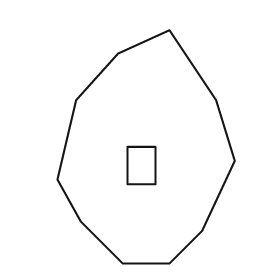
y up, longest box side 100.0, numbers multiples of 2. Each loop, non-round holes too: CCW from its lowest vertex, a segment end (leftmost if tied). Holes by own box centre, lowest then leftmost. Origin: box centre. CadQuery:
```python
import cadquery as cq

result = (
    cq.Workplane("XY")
    .moveTo(-10.0, -50.0)
    .lineTo(10.0, -50.0)
    .lineTo(24.0, -36.0)
    .lineTo(38.0, -6.0)
    .lineTo(30.0, 20.0)
    .lineTo(10.0, 50.0)
    .lineTo(-12.0, 40.0)
    .lineTo(-30.0, 20.0)
    .lineTo(-38.0, -14.0)
    .lineTo(-28.0, -32.0)
    .close()
    .moveTo(-8.0, -16.0)
    .lineTo(4.0, -16.0)
    .lineTo(4.0, 0.0)
    .lineTo(-8.0, 0.0)
    .close()
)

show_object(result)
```